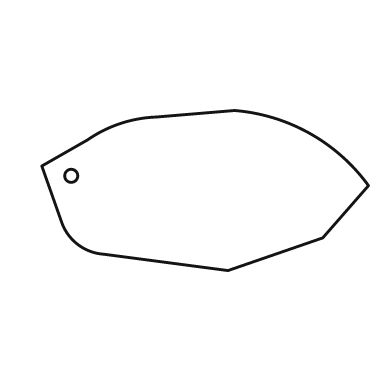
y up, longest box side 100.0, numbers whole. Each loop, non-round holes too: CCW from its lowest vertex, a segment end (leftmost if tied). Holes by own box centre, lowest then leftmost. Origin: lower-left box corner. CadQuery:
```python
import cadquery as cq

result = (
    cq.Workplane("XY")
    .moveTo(57.0, 0.0)
    .lineTo(86.0, 10.0)
    .lineTo(100.0, 26.0)
    .threePointArc((82.0, 42.0), (59.0, 49.0))
    .lineTo(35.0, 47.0)
    .threePointArc((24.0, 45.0), (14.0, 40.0))
    .lineTo(0.0, 32.0)
    .lineTo(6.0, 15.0)
    .threePointArc((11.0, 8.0), (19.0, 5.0))
    .close()
    .moveTo(9.0, 29.0)
    .circle(2.0)
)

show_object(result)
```